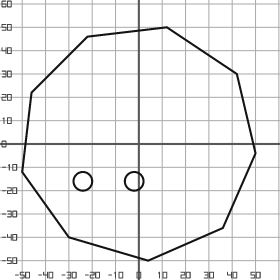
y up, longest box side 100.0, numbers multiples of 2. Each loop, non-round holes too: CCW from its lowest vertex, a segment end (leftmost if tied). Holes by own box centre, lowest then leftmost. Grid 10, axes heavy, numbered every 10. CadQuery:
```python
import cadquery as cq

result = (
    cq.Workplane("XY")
    .moveTo(4.0, -50.0)
    .lineTo(36.0, -36.0)
    .lineTo(50.0, -4.0)
    .lineTo(42.0, 30.0)
    .lineTo(12.0, 50.0)
    .lineTo(-22.0, 46.0)
    .lineTo(-46.0, 22.0)
    .lineTo(-50.0, -12.0)
    .lineTo(-30.0, -40.0)
    .close()
    .moveTo(-24.0, -16.0)
    .circle(4.0)
    .moveTo(-2.0, -16.0)
    .circle(4.0)
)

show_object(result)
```